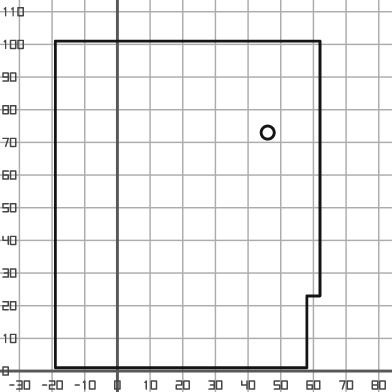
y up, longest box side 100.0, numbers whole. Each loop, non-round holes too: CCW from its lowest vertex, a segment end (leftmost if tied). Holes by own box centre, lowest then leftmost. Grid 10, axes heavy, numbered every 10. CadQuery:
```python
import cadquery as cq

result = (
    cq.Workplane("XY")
    .moveTo(-19.0, 1.0)
    .lineTo(58.0, 1.0)
    .lineTo(58.0, 23.0)
    .lineTo(62.0, 23.0)
    .lineTo(62.0, 101.0)
    .lineTo(-19.0, 101.0)
    .close()
    .moveTo(46.0, 73.0)
    .circle(2.0)
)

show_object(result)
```